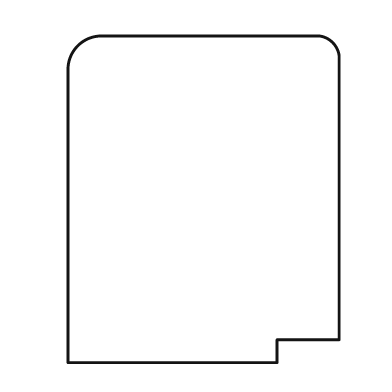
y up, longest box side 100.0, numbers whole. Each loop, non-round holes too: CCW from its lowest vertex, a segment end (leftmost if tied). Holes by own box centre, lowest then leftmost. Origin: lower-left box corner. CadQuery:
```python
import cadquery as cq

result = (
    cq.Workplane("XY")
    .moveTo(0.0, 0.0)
    .lineTo(64.0, 0.0)
    .lineTo(64.0, 7.0)
    .lineTo(83.0, 7.0)
    .lineTo(83.0, 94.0)
    .threePointArc((81.0, 98.0), (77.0, 100.0))
    .lineTo(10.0, 100.0)
    .threePointArc((3.0, 97.0), (0.0, 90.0))
    .close()
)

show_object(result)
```